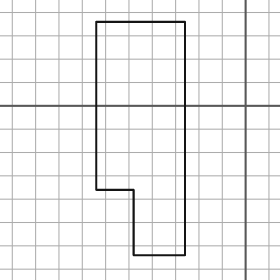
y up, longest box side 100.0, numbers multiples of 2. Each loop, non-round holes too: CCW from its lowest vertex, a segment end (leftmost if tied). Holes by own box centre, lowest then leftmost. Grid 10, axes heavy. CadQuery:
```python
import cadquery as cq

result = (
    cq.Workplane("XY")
    .moveTo(-48.0, -64.0)
    .lineTo(-26.0, -64.0)
    .lineTo(-26.0, 36.0)
    .lineTo(-64.0, 36.0)
    .lineTo(-64.0, -36.0)
    .lineTo(-48.0, -36.0)
    .close()
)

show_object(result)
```